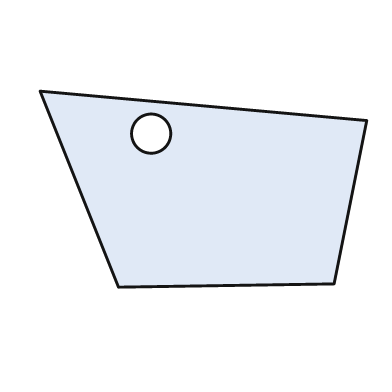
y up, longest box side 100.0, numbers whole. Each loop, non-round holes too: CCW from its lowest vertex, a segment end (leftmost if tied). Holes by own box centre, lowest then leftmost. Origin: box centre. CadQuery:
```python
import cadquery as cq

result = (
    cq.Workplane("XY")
    .moveTo(-26.0, -30.0)
    .lineTo(40.0, -29.0)
    .lineTo(50.0, 21.0)
    .lineTo(-50.0, 30.0)
    .close()
    .moveTo(-16.0, 17.0)
    .circle(6.0)
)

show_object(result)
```